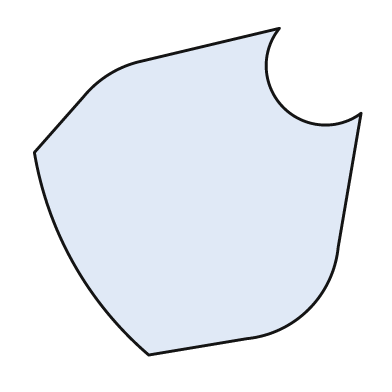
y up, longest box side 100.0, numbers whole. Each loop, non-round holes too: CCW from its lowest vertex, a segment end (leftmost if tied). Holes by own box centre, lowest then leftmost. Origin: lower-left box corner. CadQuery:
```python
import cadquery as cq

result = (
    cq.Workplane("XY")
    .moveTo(35.0, 0.0)
    .lineTo(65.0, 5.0)
    .threePointArc((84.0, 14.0), (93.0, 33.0))
    .lineTo(100.0, 74.0)
    .threePointArc((76.0, 76.0), (75.0, 100.0))
    .lineTo(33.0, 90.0)
    .threePointArc((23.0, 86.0), (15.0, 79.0))
    .lineTo(0.0, 62.0)
    .threePointArc((12.0, 28.0), (35.0, 0.0))
    .close()
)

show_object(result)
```